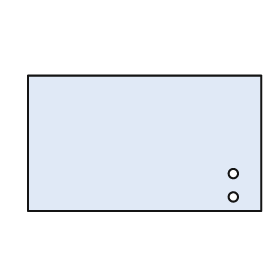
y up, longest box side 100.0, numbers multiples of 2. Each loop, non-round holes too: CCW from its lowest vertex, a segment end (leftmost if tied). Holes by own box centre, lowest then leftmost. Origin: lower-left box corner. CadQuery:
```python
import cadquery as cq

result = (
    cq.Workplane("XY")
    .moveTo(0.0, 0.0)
    .lineTo(100.0, 0.0)
    .lineTo(100.0, 58.0)
    .lineTo(0.0, 58.0)
    .close()
    .moveTo(88.0, 6.0)
    .circle(2.0)
    .moveTo(88.0, 16.0)
    .circle(2.0)
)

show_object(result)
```